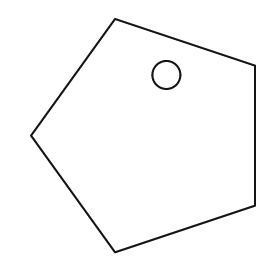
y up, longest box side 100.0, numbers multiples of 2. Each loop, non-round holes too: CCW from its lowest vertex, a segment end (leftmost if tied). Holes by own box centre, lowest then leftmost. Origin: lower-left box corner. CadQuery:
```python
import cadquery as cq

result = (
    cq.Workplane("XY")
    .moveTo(36.0, 0.0)
    .lineTo(96.0, 20.0)
    .lineTo(96.0, 80.0)
    .lineTo(36.0, 100.0)
    .lineTo(0.0, 50.0)
    .close()
    .moveTo(58.0, 76.0)
    .circle(6.0)
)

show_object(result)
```